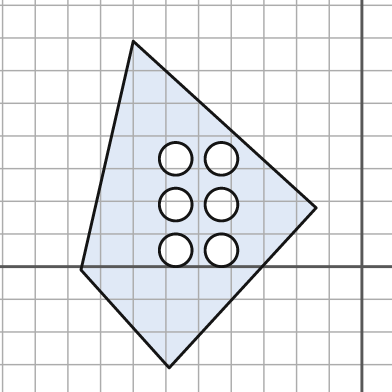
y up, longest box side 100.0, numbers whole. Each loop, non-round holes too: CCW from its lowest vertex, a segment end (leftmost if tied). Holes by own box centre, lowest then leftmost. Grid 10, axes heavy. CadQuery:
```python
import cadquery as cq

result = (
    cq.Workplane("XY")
    .moveTo(-59.0, -31.0)
    .lineTo(-14.0, 18.0)
    .lineTo(-70.0, 69.0)
    .lineTo(-86.0, -1.0)
    .close()
    .moveTo(-57.0, 5.0)
    .circle(5.0)
    .moveTo(-43.0, 5.0)
    .circle(5.0)
    .moveTo(-57.0, 19.0)
    .circle(5.0)
    .moveTo(-43.0, 19.0)
    .circle(5.0)
    .moveTo(-57.0, 33.0)
    .circle(5.0)
    .moveTo(-43.0, 33.0)
    .circle(5.0)
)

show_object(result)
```